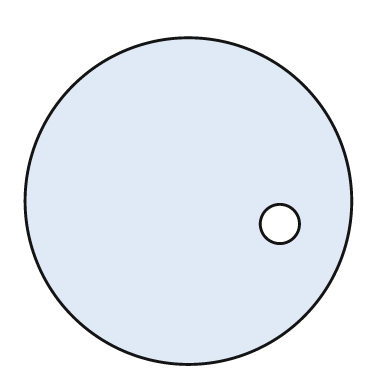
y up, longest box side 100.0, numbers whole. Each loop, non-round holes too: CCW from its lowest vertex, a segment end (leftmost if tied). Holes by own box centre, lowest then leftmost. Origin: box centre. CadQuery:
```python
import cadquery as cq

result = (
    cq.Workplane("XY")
    .moveTo(0.0, 0.0)
    .circle(50.0)
    .moveTo(28.0, -7.0)
    .circle(6.0)
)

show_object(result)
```